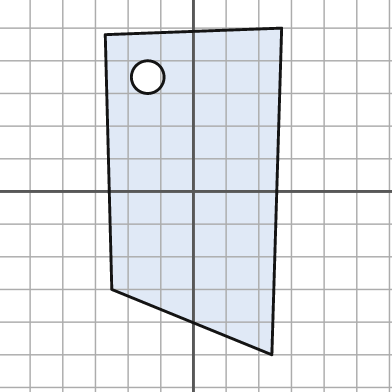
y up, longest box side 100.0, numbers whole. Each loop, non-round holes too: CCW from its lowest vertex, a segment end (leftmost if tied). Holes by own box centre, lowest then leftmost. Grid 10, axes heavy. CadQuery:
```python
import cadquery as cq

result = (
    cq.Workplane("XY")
    .moveTo(24.0, -50.0)
    .lineTo(27.0, 50.0)
    .lineTo(-27.0, 48.0)
    .lineTo(-25.0, -30.0)
    .close()
    .moveTo(-14.0, 35.0)
    .circle(5.0)
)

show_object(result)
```